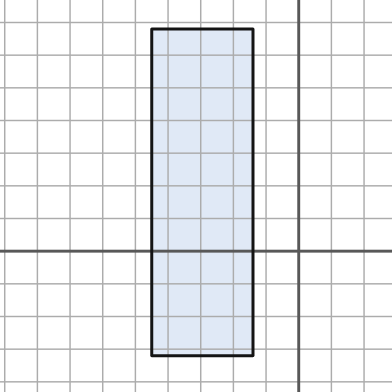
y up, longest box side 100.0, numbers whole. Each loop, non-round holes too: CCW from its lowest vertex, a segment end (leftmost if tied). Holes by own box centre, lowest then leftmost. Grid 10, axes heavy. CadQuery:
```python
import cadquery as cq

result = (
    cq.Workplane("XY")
    .moveTo(-45.0, -32.0)
    .lineTo(-14.0, -32.0)
    .lineTo(-14.0, 68.0)
    .lineTo(-45.0, 68.0)
    .close()
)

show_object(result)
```